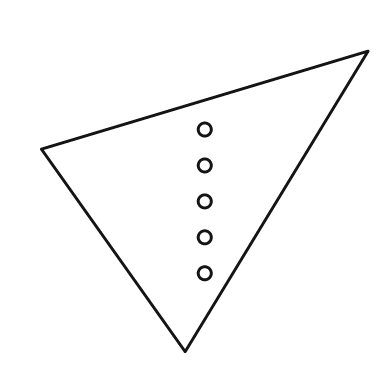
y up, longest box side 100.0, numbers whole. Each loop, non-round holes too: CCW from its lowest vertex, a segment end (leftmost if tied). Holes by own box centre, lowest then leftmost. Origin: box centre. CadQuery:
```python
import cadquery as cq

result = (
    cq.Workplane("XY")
    .moveTo(-6.0, -46.0)
    .lineTo(50.0, 46.0)
    .lineTo(-50.0, 16.0)
    .close()
    .moveTo(0.0, -22.0)
    .circle(2.0)
    .moveTo(0.0, -11.0)
    .circle(2.0)
    .moveTo(0.0, 0.0)
    .circle(2.0)
    .moveTo(0.0, 11.0)
    .circle(2.0)
    .moveTo(0.0, 22.0)
    .circle(2.0)
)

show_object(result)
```